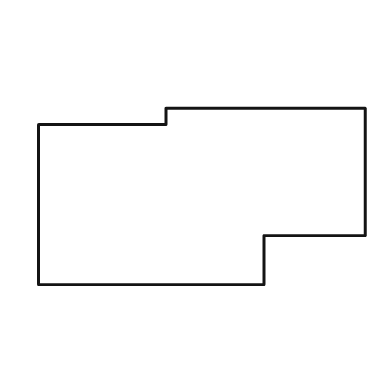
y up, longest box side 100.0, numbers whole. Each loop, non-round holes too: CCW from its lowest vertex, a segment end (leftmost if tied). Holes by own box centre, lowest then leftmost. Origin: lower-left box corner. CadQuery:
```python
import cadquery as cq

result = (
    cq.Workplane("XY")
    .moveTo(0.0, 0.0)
    .lineTo(69.0, 0.0)
    .lineTo(69.0, 15.0)
    .lineTo(100.0, 15.0)
    .lineTo(100.0, 54.0)
    .lineTo(39.0, 54.0)
    .lineTo(39.0, 49.0)
    .lineTo(0.0, 49.0)
    .close()
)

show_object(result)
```